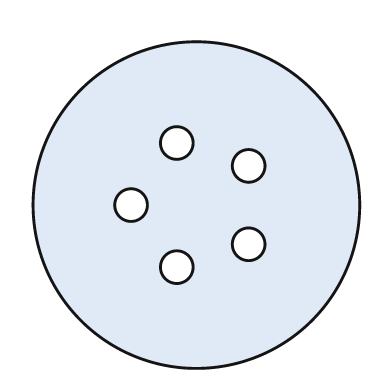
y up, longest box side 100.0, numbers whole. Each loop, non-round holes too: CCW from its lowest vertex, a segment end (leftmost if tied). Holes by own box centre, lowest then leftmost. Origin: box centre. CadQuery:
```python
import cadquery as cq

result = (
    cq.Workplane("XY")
    .moveTo(0.0, 0.0)
    .circle(50.0)
    .moveTo(-6.0, -19.0)
    .circle(5.0)
    .moveTo(16.0, -12.0)
    .circle(5.0)
    .moveTo(-20.0, 0.0)
    .circle(5.0)
    .moveTo(16.0, 12.0)
    .circle(5.0)
    .moveTo(-6.0, 19.0)
    .circle(5.0)
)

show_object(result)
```